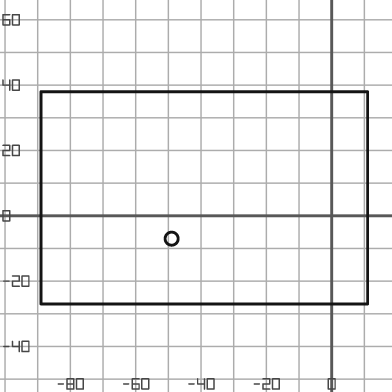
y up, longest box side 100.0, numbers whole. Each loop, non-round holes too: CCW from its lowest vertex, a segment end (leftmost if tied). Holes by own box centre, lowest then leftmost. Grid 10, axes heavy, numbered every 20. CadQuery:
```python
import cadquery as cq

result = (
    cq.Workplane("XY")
    .moveTo(-89.0, -27.0)
    .lineTo(11.0, -27.0)
    .lineTo(11.0, 38.0)
    .lineTo(-89.0, 38.0)
    .close()
    .moveTo(-49.0, -7.0)
    .circle(2.0)
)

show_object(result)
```